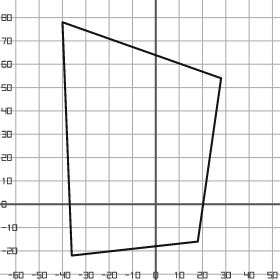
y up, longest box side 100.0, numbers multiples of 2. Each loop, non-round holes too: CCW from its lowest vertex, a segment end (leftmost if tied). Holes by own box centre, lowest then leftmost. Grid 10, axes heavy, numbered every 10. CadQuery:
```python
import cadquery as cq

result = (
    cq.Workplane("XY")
    .moveTo(-36.0, -22.0)
    .lineTo(18.0, -16.0)
    .lineTo(28.0, 54.0)
    .lineTo(-40.0, 78.0)
    .close()
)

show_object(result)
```